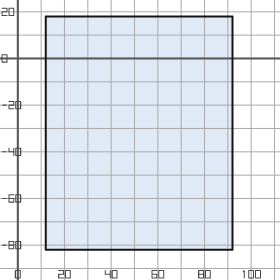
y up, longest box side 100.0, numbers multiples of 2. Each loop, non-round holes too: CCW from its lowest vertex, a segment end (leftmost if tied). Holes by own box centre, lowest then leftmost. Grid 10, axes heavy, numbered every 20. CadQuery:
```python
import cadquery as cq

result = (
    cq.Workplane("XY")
    .moveTo(12.0, -82.0)
    .lineTo(92.0, -82.0)
    .lineTo(92.0, 18.0)
    .lineTo(12.0, 18.0)
    .close()
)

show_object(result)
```